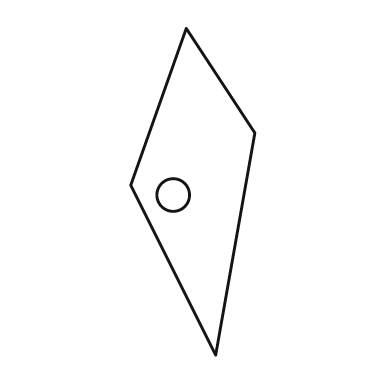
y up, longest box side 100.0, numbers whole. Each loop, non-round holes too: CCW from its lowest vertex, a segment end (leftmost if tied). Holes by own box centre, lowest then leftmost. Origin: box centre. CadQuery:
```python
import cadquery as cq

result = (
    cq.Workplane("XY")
    .moveTo(7.0, -50.0)
    .lineTo(19.0, 18.0)
    .lineTo(-2.0, 50.0)
    .lineTo(-19.0, 2.0)
    .close()
    .moveTo(-6.0, -1.0)
    .circle(5.0)
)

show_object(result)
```